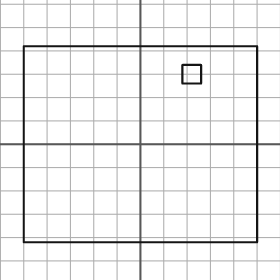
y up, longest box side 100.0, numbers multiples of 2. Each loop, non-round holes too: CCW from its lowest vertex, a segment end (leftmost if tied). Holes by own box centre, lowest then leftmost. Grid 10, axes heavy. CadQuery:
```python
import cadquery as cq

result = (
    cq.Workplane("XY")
    .moveTo(-50.0, -42.0)
    .lineTo(50.0, -42.0)
    .lineTo(50.0, 42.0)
    .lineTo(-50.0, 42.0)
    .close()
    .moveTo(18.0, 26.0)
    .lineTo(26.0, 26.0)
    .lineTo(26.0, 34.0)
    .lineTo(18.0, 34.0)
    .close()
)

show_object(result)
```